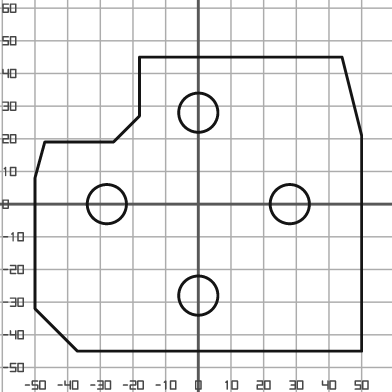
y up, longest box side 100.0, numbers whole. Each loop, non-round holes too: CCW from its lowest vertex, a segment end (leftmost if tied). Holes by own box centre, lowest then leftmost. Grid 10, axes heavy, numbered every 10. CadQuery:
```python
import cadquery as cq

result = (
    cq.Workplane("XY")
    .moveTo(-37.0, -45.0)
    .lineTo(50.0, -45.0)
    .lineTo(50.0, 21.0)
    .lineTo(44.0, 45.0)
    .lineTo(-18.0, 45.0)
    .lineTo(-18.0, 27.0)
    .lineTo(-26.0, 19.0)
    .lineTo(-47.0, 19.0)
    .lineTo(-50.0, 8.0)
    .lineTo(-50.0, -32.0)
    .close()
    .moveTo(0.0, -28.0)
    .circle(6.0)
    .moveTo(-28.0, 0.0)
    .circle(6.0)
    .moveTo(28.0, 0.0)
    .circle(6.0)
    .moveTo(0.0, 28.0)
    .circle(6.0)
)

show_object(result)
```